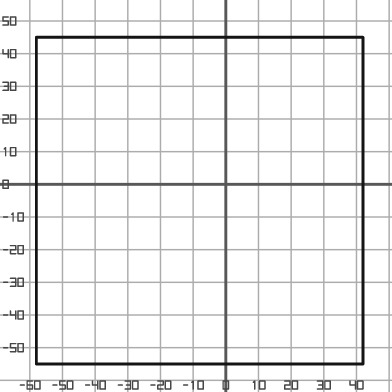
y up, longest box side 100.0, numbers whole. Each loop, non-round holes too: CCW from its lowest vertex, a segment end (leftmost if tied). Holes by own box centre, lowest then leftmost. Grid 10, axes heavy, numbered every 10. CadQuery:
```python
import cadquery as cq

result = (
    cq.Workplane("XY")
    .moveTo(-58.0, -55.0)
    .lineTo(42.0, -55.0)
    .lineTo(42.0, 45.0)
    .lineTo(-58.0, 45.0)
    .close()
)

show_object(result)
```